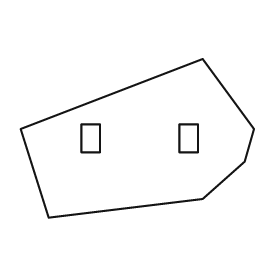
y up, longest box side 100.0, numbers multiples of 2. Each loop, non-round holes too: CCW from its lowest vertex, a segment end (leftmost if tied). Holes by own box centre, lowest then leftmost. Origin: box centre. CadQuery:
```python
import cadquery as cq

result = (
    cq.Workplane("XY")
    .moveTo(-38.0, -34.0)
    .lineTo(28.0, -26.0)
    .lineTo(46.0, -10.0)
    .lineTo(50.0, 4.0)
    .lineTo(28.0, 34.0)
    .lineTo(-50.0, 4.0)
    .close()
    .moveTo(-24.0, -6.0)
    .lineTo(-16.0, -6.0)
    .lineTo(-16.0, 6.0)
    .lineTo(-24.0, 6.0)
    .close()
    .moveTo(18.0, -6.0)
    .lineTo(26.0, -6.0)
    .lineTo(26.0, 6.0)
    .lineTo(18.0, 6.0)
    .close()
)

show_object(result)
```